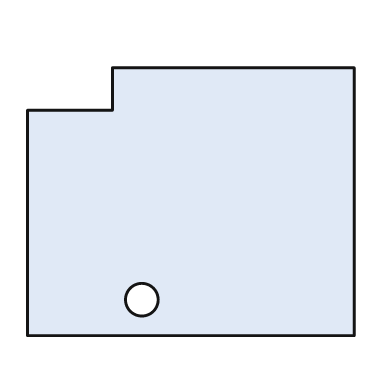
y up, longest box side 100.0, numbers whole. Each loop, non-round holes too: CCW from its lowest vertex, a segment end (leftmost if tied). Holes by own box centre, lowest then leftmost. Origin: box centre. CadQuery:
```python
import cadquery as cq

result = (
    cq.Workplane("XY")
    .moveTo(-50.0, -41.0)
    .lineTo(50.0, -41.0)
    .lineTo(50.0, 41.0)
    .lineTo(-24.0, 41.0)
    .lineTo(-24.0, 28.0)
    .lineTo(-50.0, 28.0)
    .close()
    .moveTo(-15.0, -30.0)
    .circle(5.0)
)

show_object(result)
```